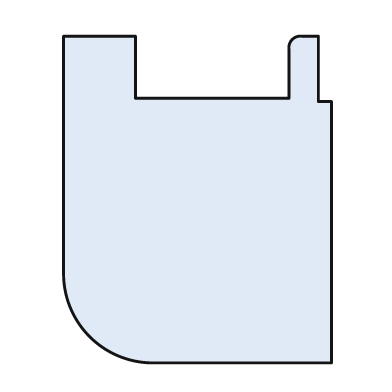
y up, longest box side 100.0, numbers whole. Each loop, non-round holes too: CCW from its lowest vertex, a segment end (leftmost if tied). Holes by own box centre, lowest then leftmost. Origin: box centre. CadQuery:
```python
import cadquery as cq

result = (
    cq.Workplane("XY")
    .moveTo(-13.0, -50.0)
    .lineTo(41.0, -50.0)
    .lineTo(41.0, 30.0)
    .lineTo(37.0, 30.0)
    .lineTo(37.0, 50.0)
    .lineTo(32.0, 50.0)
    .threePointArc((29.0, 49.0), (28.0, 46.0))
    .lineTo(28.0, 31.0)
    .lineTo(-19.0, 31.0)
    .lineTo(-19.0, 50.0)
    .lineTo(-41.0, 50.0)
    .lineTo(-41.0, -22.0)
    .threePointArc((-33.0, -42.0), (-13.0, -50.0))
    .close()
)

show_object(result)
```